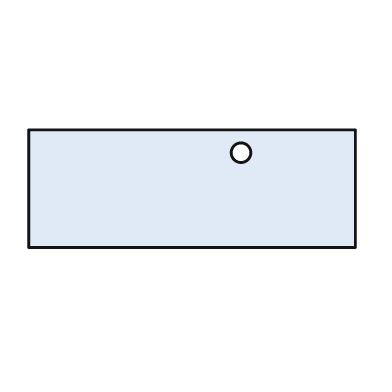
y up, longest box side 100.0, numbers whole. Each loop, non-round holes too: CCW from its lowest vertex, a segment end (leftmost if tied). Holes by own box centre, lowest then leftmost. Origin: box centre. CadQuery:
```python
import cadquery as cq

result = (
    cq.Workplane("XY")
    .moveTo(-50.0, -18.0)
    .lineTo(50.0, -18.0)
    .lineTo(50.0, 18.0)
    .lineTo(-50.0, 18.0)
    .close()
    .moveTo(15.0, 11.0)
    .circle(3.0)
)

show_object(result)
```